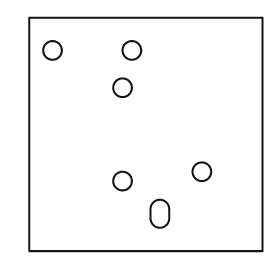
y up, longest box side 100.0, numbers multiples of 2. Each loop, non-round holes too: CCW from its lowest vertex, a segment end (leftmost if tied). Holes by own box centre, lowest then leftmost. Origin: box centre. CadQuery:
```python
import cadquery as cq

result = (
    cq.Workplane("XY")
    .moveTo(-50.0, -50.0)
    .lineTo(50.0, -50.0)
    .lineTo(50.0, 50.0)
    .lineTo(-50.0, 50.0)
    .close()
    .moveTo(2.0, -36.0)
    .threePointArc((6.0, -40.0), (10.0, -36.0))
    .lineTo(10.0, -32.0)
    .threePointArc((6.0, -28.0), (2.0, -32.0))
    .close()
    .moveTo(-10.0, -20.0)
    .circle(4.0)
    .moveTo(24.0, -16.0)
    .circle(4.0)
    .moveTo(-10.0, 20.0)
    .circle(4.0)
    .moveTo(-40.0, 36.0)
    .circle(4.0)
    .moveTo(-6.0, 36.0)
    .circle(4.0)
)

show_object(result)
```